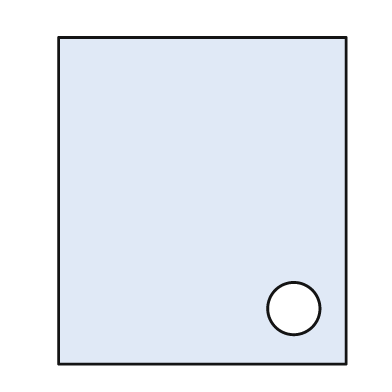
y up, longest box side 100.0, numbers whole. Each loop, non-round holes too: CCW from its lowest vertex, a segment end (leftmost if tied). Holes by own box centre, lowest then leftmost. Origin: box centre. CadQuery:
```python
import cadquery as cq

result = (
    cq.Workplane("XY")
    .moveTo(-44.0, -50.0)
    .lineTo(44.0, -50.0)
    .lineTo(44.0, 50.0)
    .lineTo(-44.0, 50.0)
    .close()
    .moveTo(28.0, -33.0)
    .circle(8.0)
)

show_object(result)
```